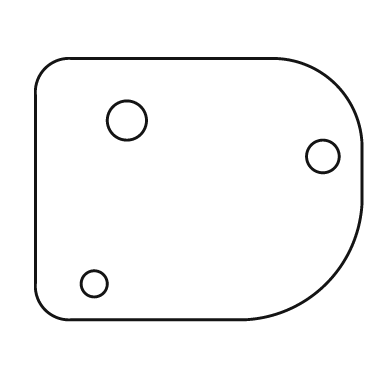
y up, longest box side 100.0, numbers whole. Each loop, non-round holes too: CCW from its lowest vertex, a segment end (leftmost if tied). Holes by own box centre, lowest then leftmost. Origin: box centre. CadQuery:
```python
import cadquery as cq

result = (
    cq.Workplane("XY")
    .moveTo(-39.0, -40.0)
    .lineTo(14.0, -40.0)
    .threePointArc((39.0, -29.0), (50.0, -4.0))
    .lineTo(50.0, 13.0)
    .threePointArc((42.0, 32.0), (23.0, 40.0))
    .lineTo(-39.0, 40.0)
    .threePointArc((-47.0, 37.0), (-50.0, 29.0))
    .lineTo(-50.0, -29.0)
    .threePointArc((-47.0, -37.0), (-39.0, -40.0))
    .close()
    .moveTo(-32.0, -29.0)
    .circle(4.0)
    .moveTo(38.0, 10.0)
    .circle(5.0)
    .moveTo(-22.0, 21.0)
    .circle(6.0)
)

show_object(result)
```